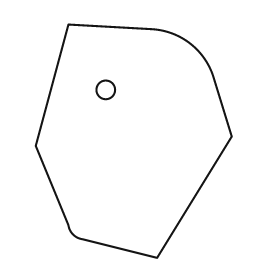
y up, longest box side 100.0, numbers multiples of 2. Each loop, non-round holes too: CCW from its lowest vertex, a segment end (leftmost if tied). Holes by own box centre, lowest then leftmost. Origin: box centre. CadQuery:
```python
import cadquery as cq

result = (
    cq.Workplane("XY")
    .moveTo(10.0, -50.0)
    .lineTo(42.0, 2.0)
    .lineTo(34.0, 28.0)
    .threePointArc((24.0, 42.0), (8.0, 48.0))
    .lineTo(-28.0, 50.0)
    .lineTo(-42.0, -2.0)
    .lineTo(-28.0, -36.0)
    .threePointArc((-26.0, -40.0), (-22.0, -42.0))
    .close()
    .moveTo(-12.0, 22.0)
    .circle(4.0)
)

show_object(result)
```